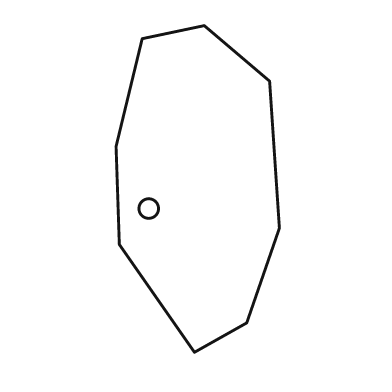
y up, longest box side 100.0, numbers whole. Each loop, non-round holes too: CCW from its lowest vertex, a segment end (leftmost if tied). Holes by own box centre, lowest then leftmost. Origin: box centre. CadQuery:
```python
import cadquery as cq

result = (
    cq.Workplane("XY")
    .moveTo(-1.0, -50.0)
    .lineTo(15.0, -41.0)
    .lineTo(25.0, -12.0)
    .lineTo(22.0, 33.0)
    .lineTo(2.0, 50.0)
    .lineTo(-17.0, 46.0)
    .lineTo(-25.0, 13.0)
    .lineTo(-24.0, -17.0)
    .close()
    .moveTo(-15.0, -6.0)
    .circle(3.0)
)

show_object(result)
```